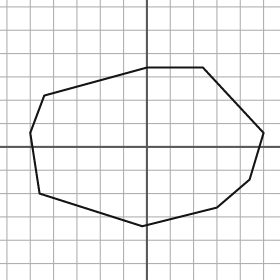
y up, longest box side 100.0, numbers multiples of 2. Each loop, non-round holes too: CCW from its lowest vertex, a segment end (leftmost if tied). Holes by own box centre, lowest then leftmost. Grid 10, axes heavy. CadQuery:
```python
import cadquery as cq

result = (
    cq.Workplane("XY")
    .moveTo(-2.0, -34.0)
    .lineTo(30.0, -26.0)
    .lineTo(44.0, -14.0)
    .lineTo(50.0, 6.0)
    .lineTo(24.0, 34.0)
    .lineTo(0.0, 34.0)
    .lineTo(-44.0, 22.0)
    .lineTo(-50.0, 6.0)
    .lineTo(-46.0, -20.0)
    .close()
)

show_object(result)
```